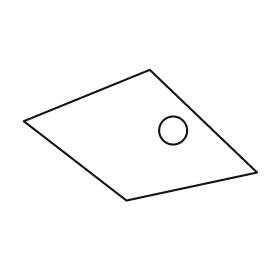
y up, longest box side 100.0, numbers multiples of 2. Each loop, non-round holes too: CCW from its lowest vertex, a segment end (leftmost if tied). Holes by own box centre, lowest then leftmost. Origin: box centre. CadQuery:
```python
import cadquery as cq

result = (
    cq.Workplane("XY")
    .moveTo(-6.0, -28.0)
    .lineTo(50.0, -16.0)
    .lineTo(4.0, 28.0)
    .lineTo(-50.0, 6.0)
    .close()
    .moveTo(14.0, 2.0)
    .circle(6.0)
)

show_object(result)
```